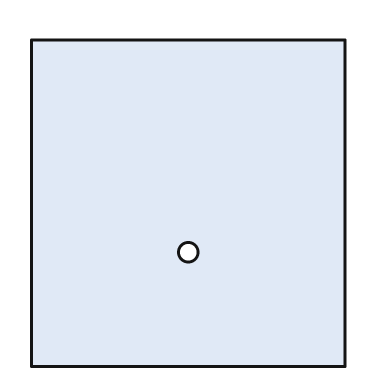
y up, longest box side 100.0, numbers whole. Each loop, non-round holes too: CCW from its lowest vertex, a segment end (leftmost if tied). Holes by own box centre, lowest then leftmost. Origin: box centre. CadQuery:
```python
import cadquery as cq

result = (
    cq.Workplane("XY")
    .moveTo(-48.0, -50.0)
    .lineTo(48.0, -50.0)
    .lineTo(48.0, 50.0)
    .lineTo(-48.0, 50.0)
    .close()
    .moveTo(0.0, -15.0)
    .circle(3.0)
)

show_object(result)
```